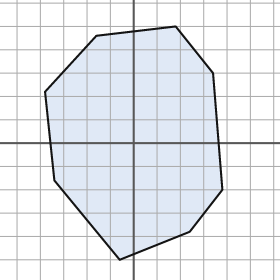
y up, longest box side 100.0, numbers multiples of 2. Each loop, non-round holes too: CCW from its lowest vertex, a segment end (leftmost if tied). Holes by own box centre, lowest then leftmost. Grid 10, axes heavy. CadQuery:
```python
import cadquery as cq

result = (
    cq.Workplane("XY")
    .moveTo(-6.0, -50.0)
    .lineTo(24.0, -38.0)
    .lineTo(38.0, -20.0)
    .lineTo(34.0, 30.0)
    .lineTo(18.0, 50.0)
    .lineTo(-16.0, 46.0)
    .lineTo(-38.0, 22.0)
    .lineTo(-34.0, -16.0)
    .close()
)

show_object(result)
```